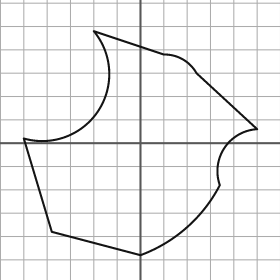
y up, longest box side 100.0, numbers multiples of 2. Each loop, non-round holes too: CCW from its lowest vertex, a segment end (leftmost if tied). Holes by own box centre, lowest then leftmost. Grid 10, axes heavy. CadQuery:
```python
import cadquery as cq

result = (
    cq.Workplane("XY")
    .moveTo(0.0, -48.0)
    .threePointArc((20.0, -36.0), (34.0, -18.0))
    .threePointArc((36.0, -2.0), (50.0, 6.0))
    .lineTo(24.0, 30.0)
    .threePointArc((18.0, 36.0), (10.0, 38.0))
    .lineTo(-20.0, 48.0)
    .threePointArc((-18.0, 14.0), (-50.0, 2.0))
    .lineTo(-38.0, -38.0)
    .close()
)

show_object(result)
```